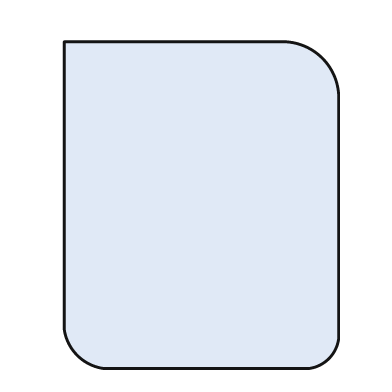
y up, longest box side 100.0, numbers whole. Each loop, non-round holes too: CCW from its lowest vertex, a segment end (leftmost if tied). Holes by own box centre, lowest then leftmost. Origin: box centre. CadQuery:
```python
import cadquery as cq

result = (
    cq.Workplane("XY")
    .moveTo(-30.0, -50.0)
    .lineTo(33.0, -50.0)
    .threePointArc((39.0, -47.0), (42.0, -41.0))
    .lineTo(42.0, 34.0)
    .threePointArc((37.0, 45.0), (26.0, 50.0))
    .lineTo(-42.0, 50.0)
    .lineTo(-42.0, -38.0)
    .threePointArc((-38.0, -46.0), (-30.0, -50.0))
    .close()
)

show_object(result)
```